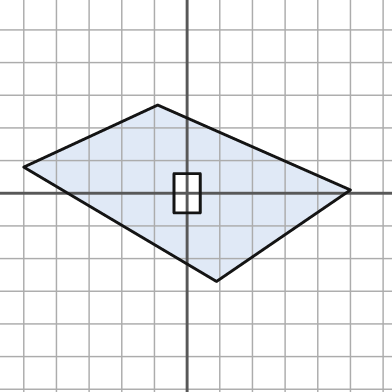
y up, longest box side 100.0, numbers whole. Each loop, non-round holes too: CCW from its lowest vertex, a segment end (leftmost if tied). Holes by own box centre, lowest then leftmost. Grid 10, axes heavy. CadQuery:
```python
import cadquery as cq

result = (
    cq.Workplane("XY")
    .moveTo(9.0, -27.0)
    .lineTo(50.0, 1.0)
    .lineTo(-9.0, 27.0)
    .lineTo(-50.0, 8.0)
    .close()
    .moveTo(-4.0, -6.0)
    .lineTo(4.0, -6.0)
    .lineTo(4.0, 6.0)
    .lineTo(-4.0, 6.0)
    .close()
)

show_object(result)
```